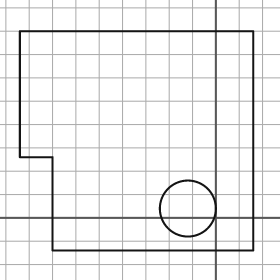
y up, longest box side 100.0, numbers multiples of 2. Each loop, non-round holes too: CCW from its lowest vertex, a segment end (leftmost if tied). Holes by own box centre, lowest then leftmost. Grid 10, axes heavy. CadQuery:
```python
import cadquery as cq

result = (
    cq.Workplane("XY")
    .moveTo(-70.0, -14.0)
    .lineTo(16.0, -14.0)
    .lineTo(16.0, 80.0)
    .lineTo(-84.0, 80.0)
    .lineTo(-84.0, 26.0)
    .lineTo(-70.0, 26.0)
    .close()
    .moveTo(-12.0, 4.0)
    .circle(12.0)
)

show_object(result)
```